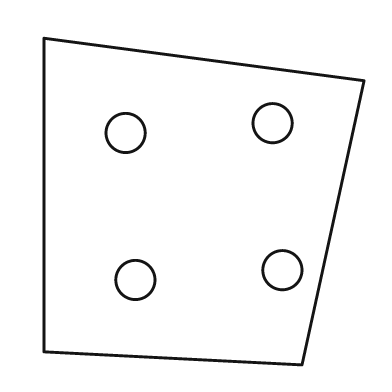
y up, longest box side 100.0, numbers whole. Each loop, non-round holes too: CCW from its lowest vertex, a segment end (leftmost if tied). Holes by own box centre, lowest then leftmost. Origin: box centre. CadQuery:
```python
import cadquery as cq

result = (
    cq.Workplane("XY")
    .moveTo(30.0, -50.0)
    .lineTo(49.0, 37.0)
    .lineTo(-49.0, 50.0)
    .lineTo(-49.0, -46.0)
    .close()
    .moveTo(-21.0, -24.0)
    .circle(6.0)
    .moveTo(24.0, -21.0)
    .circle(6.0)
    .moveTo(-24.0, 21.0)
    .circle(6.0)
    .moveTo(21.0, 24.0)
    .circle(6.0)
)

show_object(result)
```